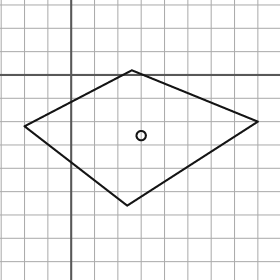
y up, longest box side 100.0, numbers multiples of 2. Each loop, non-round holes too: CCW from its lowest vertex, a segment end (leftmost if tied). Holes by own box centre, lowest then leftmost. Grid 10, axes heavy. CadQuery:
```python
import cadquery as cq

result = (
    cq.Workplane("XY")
    .moveTo(24.0, -56.0)
    .lineTo(80.0, -20.0)
    .lineTo(26.0, 2.0)
    .lineTo(-20.0, -22.0)
    .close()
    .moveTo(30.0, -26.0)
    .circle(2.0)
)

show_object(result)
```